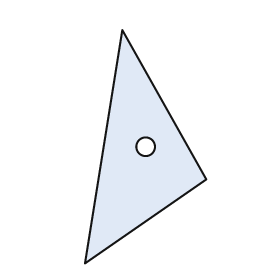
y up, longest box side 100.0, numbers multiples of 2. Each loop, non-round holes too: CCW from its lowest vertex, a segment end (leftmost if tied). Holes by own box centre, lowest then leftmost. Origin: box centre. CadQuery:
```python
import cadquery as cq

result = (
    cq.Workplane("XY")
    .moveTo(-26.0, -50.0)
    .lineTo(26.0, -14.0)
    .lineTo(-10.0, 50.0)
    .close()
    .moveTo(0.0, 0.0)
    .circle(4.0)
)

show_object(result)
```